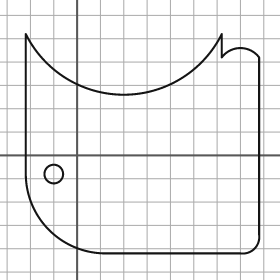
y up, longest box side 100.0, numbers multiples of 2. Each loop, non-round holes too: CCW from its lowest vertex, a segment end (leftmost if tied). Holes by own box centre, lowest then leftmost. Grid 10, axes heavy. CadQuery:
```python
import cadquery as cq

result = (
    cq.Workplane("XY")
    .moveTo(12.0, -42.0)
    .lineTo(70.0, -42.0)
    .threePointArc((76.0, -40.0), (78.0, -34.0))
    .lineTo(78.0, 42.0)
    .threePointArc((70.0, 46.0), (62.0, 42.0))
    .lineTo(62.0, 52.0)
    .threePointArc((20.0, 26.0), (-22.0, 52.0))
    .lineTo(-22.0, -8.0)
    .threePointArc((-12.0, -32.0), (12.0, -42.0))
    .close()
    .moveTo(-10.0, -8.0)
    .circle(4.0)
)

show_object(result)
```